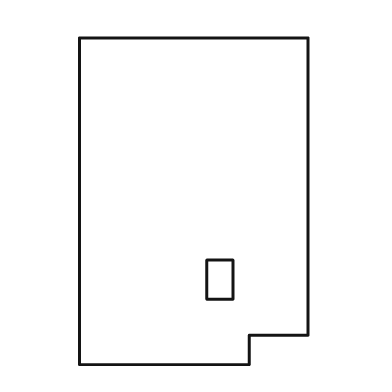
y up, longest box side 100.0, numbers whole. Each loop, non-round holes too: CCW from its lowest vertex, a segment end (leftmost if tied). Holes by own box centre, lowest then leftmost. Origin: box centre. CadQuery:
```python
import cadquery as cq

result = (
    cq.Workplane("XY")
    .moveTo(-35.0, -50.0)
    .lineTo(17.0, -50.0)
    .lineTo(17.0, -41.0)
    .lineTo(35.0, -41.0)
    .lineTo(35.0, 50.0)
    .lineTo(-35.0, 50.0)
    .close()
    .moveTo(4.0, -30.0)
    .lineTo(12.0, -30.0)
    .lineTo(12.0, -18.0)
    .lineTo(4.0, -18.0)
    .close()
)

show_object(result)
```